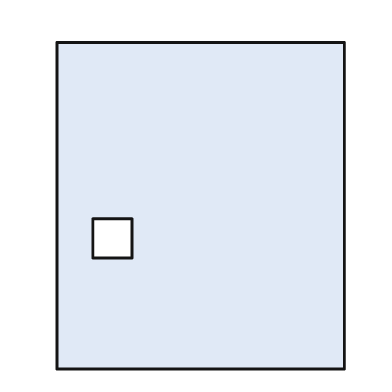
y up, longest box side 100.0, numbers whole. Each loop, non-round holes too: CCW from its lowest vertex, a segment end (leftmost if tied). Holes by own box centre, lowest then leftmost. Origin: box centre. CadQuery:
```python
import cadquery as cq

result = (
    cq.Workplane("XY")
    .moveTo(-44.0, -50.0)
    .lineTo(44.0, -50.0)
    .lineTo(44.0, 50.0)
    .lineTo(-44.0, 50.0)
    .close()
    .moveTo(-33.0, -16.0)
    .lineTo(-21.0, -16.0)
    .lineTo(-21.0, -4.0)
    .lineTo(-33.0, -4.0)
    .close()
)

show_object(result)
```